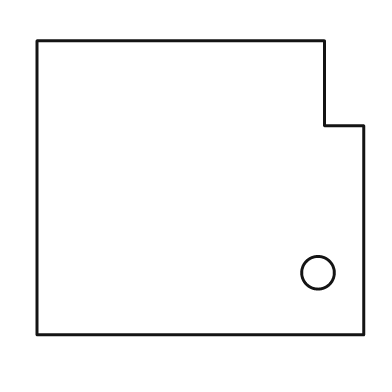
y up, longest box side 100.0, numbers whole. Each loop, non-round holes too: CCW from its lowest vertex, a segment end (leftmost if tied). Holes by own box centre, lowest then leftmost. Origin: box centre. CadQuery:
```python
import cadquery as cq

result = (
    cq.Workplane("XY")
    .moveTo(-50.0, -45.0)
    .lineTo(50.0, -45.0)
    .lineTo(50.0, 19.0)
    .lineTo(38.0, 19.0)
    .lineTo(38.0, 45.0)
    .lineTo(-50.0, 45.0)
    .close()
    .moveTo(36.0, -26.0)
    .circle(5.0)
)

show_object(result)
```